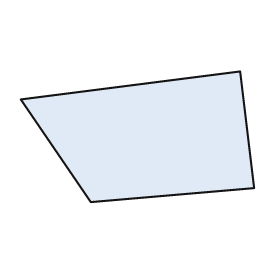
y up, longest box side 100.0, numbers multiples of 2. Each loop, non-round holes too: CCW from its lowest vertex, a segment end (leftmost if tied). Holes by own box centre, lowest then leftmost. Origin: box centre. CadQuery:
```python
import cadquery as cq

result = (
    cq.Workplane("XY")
    .moveTo(-20.0, -28.0)
    .lineTo(50.0, -22.0)
    .lineTo(44.0, 28.0)
    .lineTo(-50.0, 16.0)
    .close()
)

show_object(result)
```